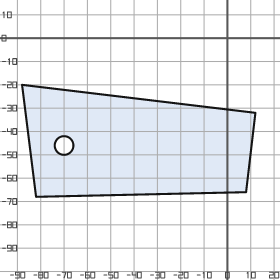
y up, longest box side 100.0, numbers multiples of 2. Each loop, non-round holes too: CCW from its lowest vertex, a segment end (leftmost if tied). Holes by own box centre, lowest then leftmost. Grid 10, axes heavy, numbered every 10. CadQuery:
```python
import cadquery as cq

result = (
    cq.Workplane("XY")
    .moveTo(-82.0, -68.0)
    .lineTo(8.0, -66.0)
    .lineTo(12.0, -32.0)
    .lineTo(-88.0, -20.0)
    .close()
    .moveTo(-70.0, -46.0)
    .circle(4.0)
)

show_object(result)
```